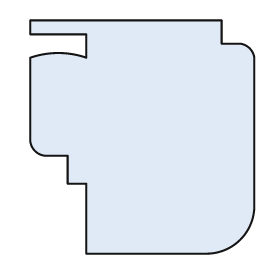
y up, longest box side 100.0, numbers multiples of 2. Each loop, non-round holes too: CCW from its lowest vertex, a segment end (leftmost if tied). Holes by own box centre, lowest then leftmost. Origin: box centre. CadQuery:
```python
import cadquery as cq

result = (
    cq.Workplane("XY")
    .moveTo(-24.0, -50.0)
    .lineTo(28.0, -50.0)
    .threePointArc((42.0, -44.0), (48.0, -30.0))
    .lineTo(48.0, 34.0)
    .threePointArc((46.0, 38.0), (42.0, 40.0))
    .lineTo(34.0, 40.0)
    .lineTo(34.0, 50.0)
    .lineTo(-48.0, 50.0)
    .lineTo(-48.0, 44.0)
    .lineTo(-24.0, 44.0)
    .lineTo(-24.0, 34.0)
    .threePointArc((-36.0, 36.0), (-48.0, 34.0))
    .lineTo(-48.0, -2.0)
    .threePointArc((-46.0, -6.0), (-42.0, -8.0))
    .lineTo(-32.0, -8.0)
    .lineTo(-32.0, -20.0)
    .lineTo(-24.0, -20.0)
    .close()
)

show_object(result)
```